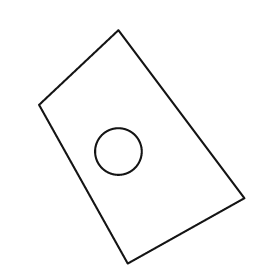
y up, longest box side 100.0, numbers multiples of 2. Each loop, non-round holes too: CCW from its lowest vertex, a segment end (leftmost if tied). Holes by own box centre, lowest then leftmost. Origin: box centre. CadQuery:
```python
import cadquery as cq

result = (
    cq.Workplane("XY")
    .moveTo(-6.0, -50.0)
    .lineTo(44.0, -22.0)
    .lineTo(-10.0, 50.0)
    .lineTo(-44.0, 18.0)
    .close()
    .moveTo(-10.0, -2.0)
    .circle(10.0)
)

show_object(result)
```